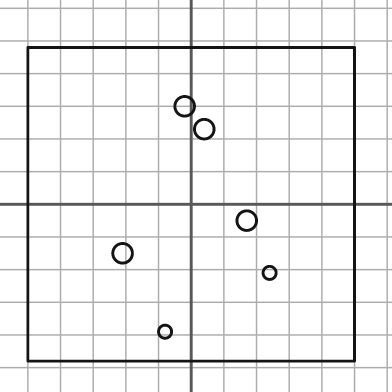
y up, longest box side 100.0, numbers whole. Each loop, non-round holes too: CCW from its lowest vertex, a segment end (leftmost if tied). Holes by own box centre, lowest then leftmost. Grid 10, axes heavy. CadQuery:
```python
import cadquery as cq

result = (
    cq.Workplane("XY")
    .moveTo(-50.0, -48.0)
    .lineTo(50.0, -48.0)
    .lineTo(50.0, 48.0)
    .lineTo(-50.0, 48.0)
    .close()
    .moveTo(-8.0, -39.0)
    .circle(2.0)
    .moveTo(24.0, -21.0)
    .circle(2.0)
    .moveTo(-21.0, -15.0)
    .circle(3.0)
    .moveTo(17.0, -5.0)
    .circle(3.0)
    .moveTo(4.0, 23.0)
    .circle(3.0)
    .moveTo(-2.0, 30.0)
    .circle(3.0)
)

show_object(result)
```